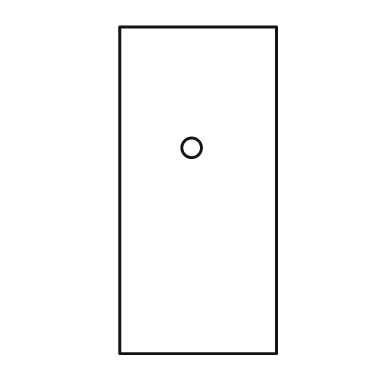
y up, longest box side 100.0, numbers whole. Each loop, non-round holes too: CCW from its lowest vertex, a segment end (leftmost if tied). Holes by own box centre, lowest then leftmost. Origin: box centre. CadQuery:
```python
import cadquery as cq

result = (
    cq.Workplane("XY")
    .moveTo(-24.0, -50.0)
    .lineTo(24.0, -50.0)
    .lineTo(24.0, 50.0)
    .lineTo(-24.0, 50.0)
    .close()
    .moveTo(-2.0, 13.0)
    .circle(3.0)
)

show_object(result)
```